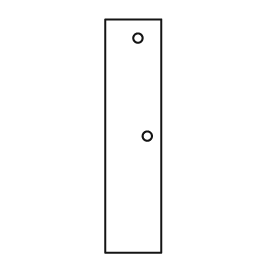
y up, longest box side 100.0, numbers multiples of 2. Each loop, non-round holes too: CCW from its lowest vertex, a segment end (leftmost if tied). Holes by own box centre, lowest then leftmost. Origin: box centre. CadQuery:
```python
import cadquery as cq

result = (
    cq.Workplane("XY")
    .moveTo(-12.0, -50.0)
    .lineTo(12.0, -50.0)
    .lineTo(12.0, 50.0)
    .lineTo(-12.0, 50.0)
    .close()
    .moveTo(6.0, 0.0)
    .circle(2.0)
    .moveTo(2.0, 42.0)
    .circle(2.0)
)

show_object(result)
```